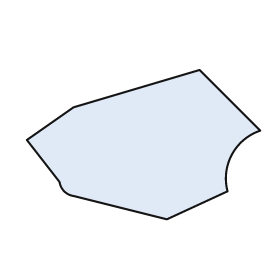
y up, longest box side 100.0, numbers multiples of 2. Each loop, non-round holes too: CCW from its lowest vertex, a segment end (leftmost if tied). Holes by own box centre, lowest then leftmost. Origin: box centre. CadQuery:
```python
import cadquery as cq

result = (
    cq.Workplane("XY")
    .moveTo(10.0, -32.0)
    .lineTo(36.0, -20.0)
    .threePointArc((38.0, -4.0), (50.0, 6.0))
    .lineTo(24.0, 32.0)
    .lineTo(-30.0, 16.0)
    .lineTo(-50.0, 2.0)
    .lineTo(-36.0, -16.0)
    .threePointArc((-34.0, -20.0), (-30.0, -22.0))
    .close()
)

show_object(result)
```